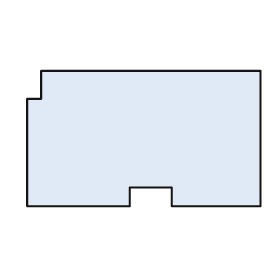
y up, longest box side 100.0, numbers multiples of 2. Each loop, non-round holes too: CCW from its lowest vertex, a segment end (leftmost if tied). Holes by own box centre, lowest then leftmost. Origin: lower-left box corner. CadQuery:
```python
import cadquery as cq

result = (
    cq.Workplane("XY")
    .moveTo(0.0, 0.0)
    .lineTo(44.0, 0.0)
    .lineTo(44.0, 8.0)
    .lineTo(62.0, 8.0)
    .lineTo(62.0, 0.0)
    .lineTo(100.0, 0.0)
    .lineTo(100.0, 58.0)
    .lineTo(6.0, 58.0)
    .lineTo(6.0, 46.0)
    .lineTo(0.0, 46.0)
    .close()
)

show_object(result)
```